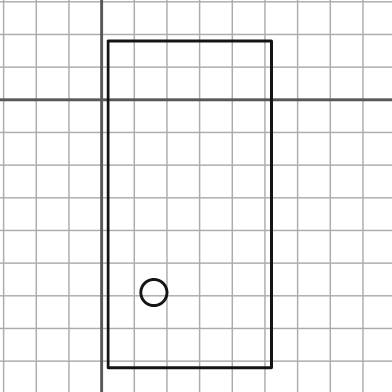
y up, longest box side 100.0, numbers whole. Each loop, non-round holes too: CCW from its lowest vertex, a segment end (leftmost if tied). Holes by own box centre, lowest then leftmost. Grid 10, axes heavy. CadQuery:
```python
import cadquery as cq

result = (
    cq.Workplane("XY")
    .moveTo(2.0, -82.0)
    .lineTo(52.0, -82.0)
    .lineTo(52.0, 18.0)
    .lineTo(2.0, 18.0)
    .close()
    .moveTo(16.0, -59.0)
    .circle(4.0)
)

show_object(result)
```